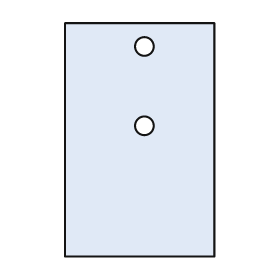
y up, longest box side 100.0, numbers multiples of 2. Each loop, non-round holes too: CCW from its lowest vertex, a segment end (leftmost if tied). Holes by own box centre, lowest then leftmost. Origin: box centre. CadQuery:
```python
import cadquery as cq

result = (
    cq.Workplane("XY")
    .moveTo(-32.0, -50.0)
    .lineTo(32.0, -50.0)
    .lineTo(32.0, 50.0)
    .lineTo(-32.0, 50.0)
    .close()
    .moveTo(2.0, 6.0)
    .circle(4.0)
    .moveTo(2.0, 40.0)
    .circle(4.0)
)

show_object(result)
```